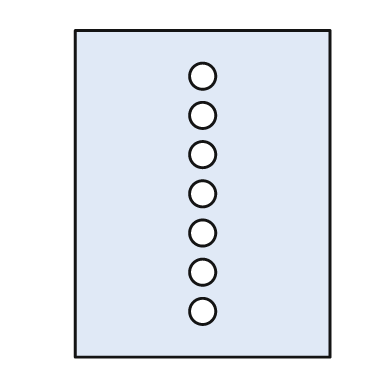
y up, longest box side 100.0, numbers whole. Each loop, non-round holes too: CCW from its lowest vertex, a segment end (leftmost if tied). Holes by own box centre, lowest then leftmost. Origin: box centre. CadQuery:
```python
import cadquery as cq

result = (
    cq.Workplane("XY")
    .moveTo(-39.0, -50.0)
    .lineTo(39.0, -50.0)
    .lineTo(39.0, 50.0)
    .lineTo(-39.0, 50.0)
    .close()
    .moveTo(0.0, -36.0)
    .circle(4.0)
    .moveTo(0.0, -24.0)
    .circle(4.0)
    .moveTo(0.0, -12.0)
    .circle(4.0)
    .moveTo(0.0, 0.0)
    .circle(4.0)
    .moveTo(0.0, 12.0)
    .circle(4.0)
    .moveTo(0.0, 24.0)
    .circle(4.0)
    .moveTo(0.0, 36.0)
    .circle(4.0)
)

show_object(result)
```